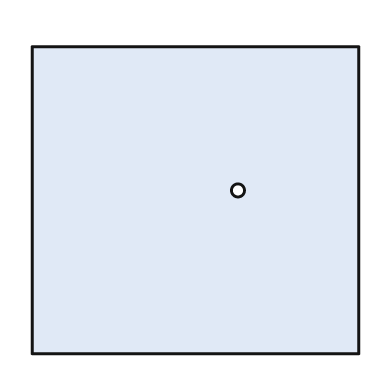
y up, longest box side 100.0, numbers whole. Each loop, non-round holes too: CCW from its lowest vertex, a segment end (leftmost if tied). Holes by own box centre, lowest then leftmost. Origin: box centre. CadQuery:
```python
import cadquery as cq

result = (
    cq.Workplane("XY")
    .moveTo(-50.0, -47.0)
    .lineTo(50.0, -47.0)
    .lineTo(50.0, 47.0)
    .lineTo(-50.0, 47.0)
    .close()
    .moveTo(13.0, 3.0)
    .circle(2.0)
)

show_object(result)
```